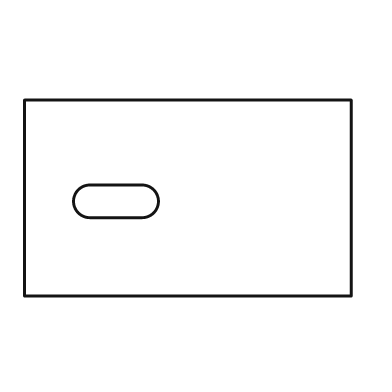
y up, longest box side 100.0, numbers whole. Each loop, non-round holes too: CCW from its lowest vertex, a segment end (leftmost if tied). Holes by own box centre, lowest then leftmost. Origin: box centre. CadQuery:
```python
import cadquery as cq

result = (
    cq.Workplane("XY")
    .moveTo(-50.0, -30.0)
    .lineTo(50.0, -30.0)
    .lineTo(50.0, 30.0)
    .lineTo(-50.0, 30.0)
    .close()
    .moveTo(-30.0, -6.0)
    .lineTo(-14.0, -6.0)
    .threePointArc((-9.0, -1.0), (-14.0, 4.0))
    .lineTo(-30.0, 4.0)
    .threePointArc((-35.0, -1.0), (-30.0, -6.0))
    .close()
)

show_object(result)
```